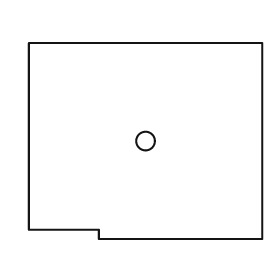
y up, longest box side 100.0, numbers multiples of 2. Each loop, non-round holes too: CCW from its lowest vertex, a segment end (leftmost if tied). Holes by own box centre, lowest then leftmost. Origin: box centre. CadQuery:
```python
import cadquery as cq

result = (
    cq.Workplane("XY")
    .moveTo(-20.0, -42.0)
    .lineTo(50.0, -42.0)
    .lineTo(50.0, 42.0)
    .lineTo(-50.0, 42.0)
    .lineTo(-50.0, -38.0)
    .lineTo(-20.0, -38.0)
    .close()
    .moveTo(0.0, 0.0)
    .circle(4.0)
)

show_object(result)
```